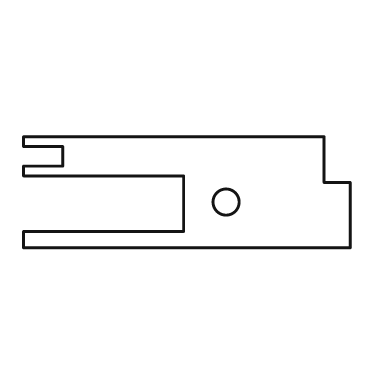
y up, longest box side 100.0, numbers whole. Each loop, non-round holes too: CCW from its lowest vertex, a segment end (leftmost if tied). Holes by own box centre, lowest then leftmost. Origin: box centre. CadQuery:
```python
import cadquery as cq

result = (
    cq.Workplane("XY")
    .moveTo(-50.0, -17.0)
    .lineTo(50.0, -17.0)
    .lineTo(50.0, 3.0)
    .lineTo(42.0, 3.0)
    .lineTo(42.0, 17.0)
    .lineTo(-50.0, 17.0)
    .lineTo(-50.0, 14.0)
    .lineTo(-38.0, 14.0)
    .lineTo(-38.0, 8.0)
    .lineTo(-50.0, 8.0)
    .lineTo(-50.0, 5.0)
    .lineTo(-1.0, 5.0)
    .lineTo(-1.0, -12.0)
    .lineTo(-50.0, -12.0)
    .close()
    .moveTo(12.0, -3.0)
    .circle(4.0)
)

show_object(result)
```